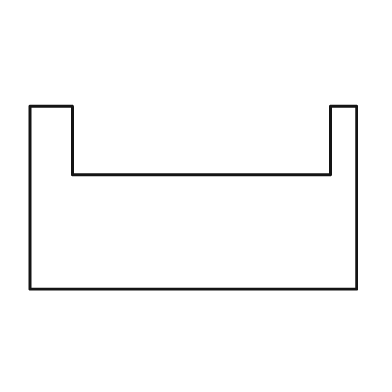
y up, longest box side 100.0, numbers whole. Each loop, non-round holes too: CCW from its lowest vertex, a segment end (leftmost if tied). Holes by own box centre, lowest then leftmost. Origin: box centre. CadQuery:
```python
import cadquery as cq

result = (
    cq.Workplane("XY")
    .moveTo(-50.0, -28.0)
    .lineTo(50.0, -28.0)
    .lineTo(50.0, 28.0)
    .lineTo(42.0, 28.0)
    .lineTo(42.0, 7.0)
    .lineTo(-37.0, 7.0)
    .lineTo(-37.0, 28.0)
    .lineTo(-50.0, 28.0)
    .close()
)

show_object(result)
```